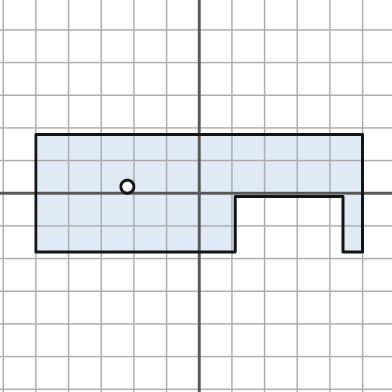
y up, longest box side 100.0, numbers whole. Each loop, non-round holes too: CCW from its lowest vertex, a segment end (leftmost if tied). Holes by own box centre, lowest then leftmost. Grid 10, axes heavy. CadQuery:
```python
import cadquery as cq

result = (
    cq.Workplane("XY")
    .moveTo(-50.0, -18.0)
    .lineTo(11.0, -18.0)
    .lineTo(11.0, -1.0)
    .lineTo(44.0, -1.0)
    .lineTo(44.0, -18.0)
    .lineTo(50.0, -18.0)
    .lineTo(50.0, 18.0)
    .lineTo(-50.0, 18.0)
    .close()
    .moveTo(-22.0, 2.0)
    .circle(2.0)
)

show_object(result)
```